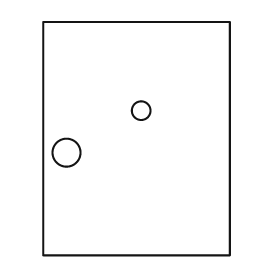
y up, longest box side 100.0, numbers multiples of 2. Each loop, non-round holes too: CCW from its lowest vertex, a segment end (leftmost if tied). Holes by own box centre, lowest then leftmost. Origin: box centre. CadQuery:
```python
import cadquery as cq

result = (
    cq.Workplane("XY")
    .moveTo(-40.0, -50.0)
    .lineTo(40.0, -50.0)
    .lineTo(40.0, 50.0)
    .lineTo(-40.0, 50.0)
    .close()
    .moveTo(-30.0, -6.0)
    .circle(6.0)
    .moveTo(2.0, 12.0)
    .circle(4.0)
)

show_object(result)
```